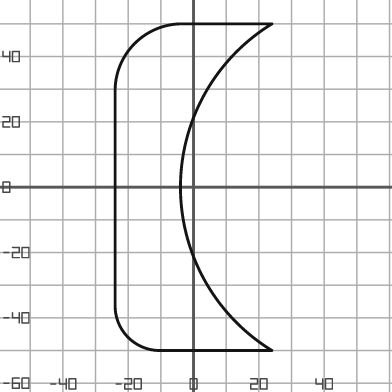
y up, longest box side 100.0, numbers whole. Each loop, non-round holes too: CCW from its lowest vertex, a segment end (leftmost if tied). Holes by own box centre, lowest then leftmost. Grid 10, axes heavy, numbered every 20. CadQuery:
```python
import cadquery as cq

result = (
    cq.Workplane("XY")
    .moveTo(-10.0, -50.0)
    .lineTo(24.0, -50.0)
    .threePointArc((-4.0, 0.0), (24.0, 50.0))
    .lineTo(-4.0, 50.0)
    .threePointArc((-18.0, 44.0), (-24.0, 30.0))
    .lineTo(-24.0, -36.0)
    .threePointArc((-20.0, -46.0), (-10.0, -50.0))
    .close()
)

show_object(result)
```